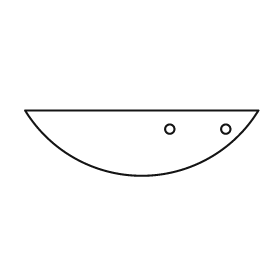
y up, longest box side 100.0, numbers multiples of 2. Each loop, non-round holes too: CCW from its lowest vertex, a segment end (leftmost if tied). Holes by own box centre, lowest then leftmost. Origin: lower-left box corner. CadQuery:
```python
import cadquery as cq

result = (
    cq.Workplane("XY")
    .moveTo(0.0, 28.0)
    .threePointArc((50.0, 0.0), (100.0, 28.0))
    .close()
    .moveTo(62.0, 20.0)
    .circle(2.0)
    .moveTo(86.0, 20.0)
    .circle(2.0)
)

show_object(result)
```